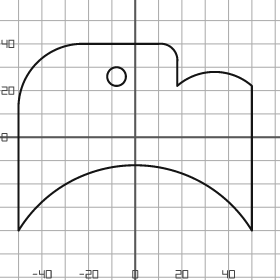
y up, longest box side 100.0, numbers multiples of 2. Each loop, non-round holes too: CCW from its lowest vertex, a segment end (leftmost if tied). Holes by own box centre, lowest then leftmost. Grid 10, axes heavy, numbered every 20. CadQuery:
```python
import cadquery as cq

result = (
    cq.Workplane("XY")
    .moveTo(-50.0, -40.0)
    .threePointArc((0.0, -12.0), (50.0, -40.0))
    .lineTo(50.0, 22.0)
    .threePointArc((34.0, 28.0), (18.0, 22.0))
    .lineTo(18.0, 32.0)
    .threePointArc((16.0, 38.0), (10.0, 40.0))
    .lineTo(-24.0, 40.0)
    .threePointArc((-42.0, 32.0), (-50.0, 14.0))
    .close()
    .moveTo(-8.0, 26.0)
    .circle(4.0)
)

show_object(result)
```